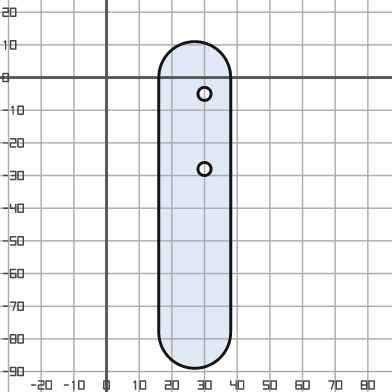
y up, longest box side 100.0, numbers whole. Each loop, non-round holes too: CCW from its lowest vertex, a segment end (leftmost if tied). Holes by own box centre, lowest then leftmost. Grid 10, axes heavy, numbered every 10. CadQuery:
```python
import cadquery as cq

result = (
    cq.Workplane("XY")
    .moveTo(16.0, -78.0)
    .threePointArc((27.0, -89.0), (38.0, -78.0))
    .lineTo(38.0, 0.0)
    .threePointArc((27.0, 11.0), (16.0, 0.0))
    .close()
    .moveTo(30.0, -28.0)
    .circle(2.0)
    .moveTo(30.0, -5.0)
    .circle(2.0)
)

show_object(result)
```